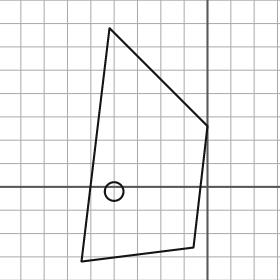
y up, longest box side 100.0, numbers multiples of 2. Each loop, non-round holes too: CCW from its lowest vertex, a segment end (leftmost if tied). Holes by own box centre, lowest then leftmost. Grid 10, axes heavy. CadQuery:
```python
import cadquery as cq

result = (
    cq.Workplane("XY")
    .moveTo(-54.0, -32.0)
    .lineTo(-6.0, -26.0)
    .lineTo(0.0, 26.0)
    .lineTo(-42.0, 68.0)
    .close()
    .moveTo(-40.0, -2.0)
    .circle(4.0)
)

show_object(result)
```